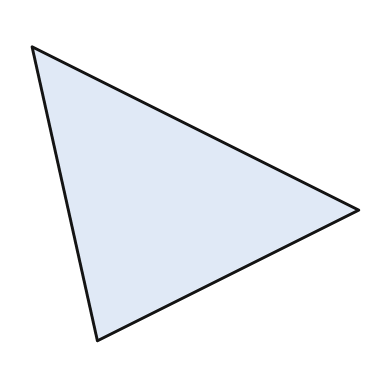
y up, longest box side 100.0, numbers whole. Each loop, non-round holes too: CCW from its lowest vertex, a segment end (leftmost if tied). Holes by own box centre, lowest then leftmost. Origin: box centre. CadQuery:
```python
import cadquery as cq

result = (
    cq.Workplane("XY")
    .moveTo(-30.0, -45.0)
    .lineTo(50.0, -5.0)
    .lineTo(-50.0, 45.0)
    .close()
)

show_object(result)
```